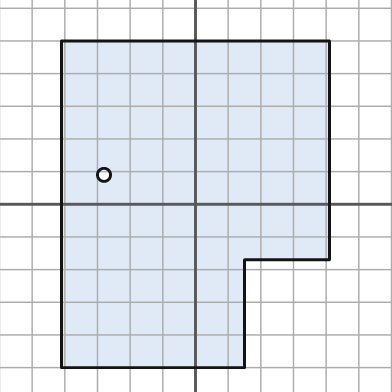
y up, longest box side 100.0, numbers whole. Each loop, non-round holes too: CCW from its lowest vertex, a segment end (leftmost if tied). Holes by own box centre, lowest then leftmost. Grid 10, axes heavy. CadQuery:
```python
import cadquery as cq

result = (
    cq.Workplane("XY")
    .moveTo(-41.0, -50.0)
    .lineTo(15.0, -50.0)
    .lineTo(15.0, -17.0)
    .lineTo(41.0, -17.0)
    .lineTo(41.0, 50.0)
    .lineTo(-41.0, 50.0)
    .close()
    .moveTo(-28.0, 9.0)
    .circle(2.0)
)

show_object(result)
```